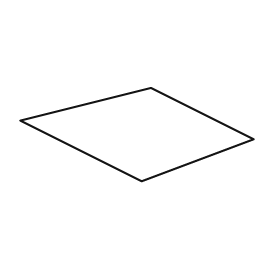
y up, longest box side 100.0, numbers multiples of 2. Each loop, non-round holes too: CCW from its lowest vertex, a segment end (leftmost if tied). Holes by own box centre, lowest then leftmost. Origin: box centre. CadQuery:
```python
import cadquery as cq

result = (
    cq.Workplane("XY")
    .moveTo(2.0, -20.0)
    .lineTo(50.0, -2.0)
    .lineTo(6.0, 20.0)
    .lineTo(-50.0, 6.0)
    .close()
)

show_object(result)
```